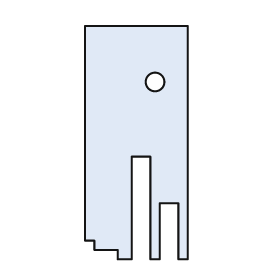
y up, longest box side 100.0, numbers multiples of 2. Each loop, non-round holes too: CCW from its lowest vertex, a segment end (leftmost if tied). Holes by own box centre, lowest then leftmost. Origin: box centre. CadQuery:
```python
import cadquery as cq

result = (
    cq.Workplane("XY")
    .moveTo(-8.0, -50.0)
    .lineTo(-2.0, -50.0)
    .lineTo(-2.0, -6.0)
    .lineTo(6.0, -6.0)
    .lineTo(6.0, -50.0)
    .lineTo(10.0, -50.0)
    .lineTo(10.0, -26.0)
    .lineTo(18.0, -26.0)
    .lineTo(18.0, -50.0)
    .lineTo(22.0, -50.0)
    .lineTo(22.0, 50.0)
    .lineTo(-22.0, 50.0)
    .lineTo(-22.0, -42.0)
    .lineTo(-18.0, -42.0)
    .lineTo(-18.0, -46.0)
    .lineTo(-8.0, -46.0)
    .close()
    .moveTo(8.0, 26.0)
    .circle(4.0)
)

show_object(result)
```